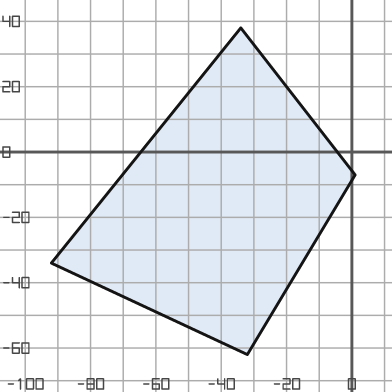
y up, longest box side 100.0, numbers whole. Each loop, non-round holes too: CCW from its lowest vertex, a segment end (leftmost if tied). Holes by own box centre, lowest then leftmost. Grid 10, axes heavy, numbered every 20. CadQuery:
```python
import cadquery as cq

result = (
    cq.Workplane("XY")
    .moveTo(-32.0, -62.0)
    .lineTo(1.0, -7.0)
    .lineTo(-34.0, 38.0)
    .lineTo(-92.0, -34.0)
    .close()
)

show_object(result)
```